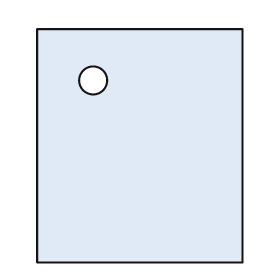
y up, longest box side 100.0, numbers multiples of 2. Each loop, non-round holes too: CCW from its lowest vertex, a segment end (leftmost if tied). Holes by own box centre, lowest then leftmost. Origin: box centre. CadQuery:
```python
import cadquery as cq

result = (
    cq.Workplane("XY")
    .moveTo(-44.0, -50.0)
    .lineTo(44.0, -50.0)
    .lineTo(44.0, 50.0)
    .lineTo(-44.0, 50.0)
    .close()
    .moveTo(-20.0, 28.0)
    .circle(6.0)
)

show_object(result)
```